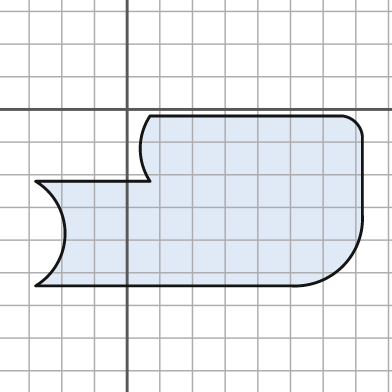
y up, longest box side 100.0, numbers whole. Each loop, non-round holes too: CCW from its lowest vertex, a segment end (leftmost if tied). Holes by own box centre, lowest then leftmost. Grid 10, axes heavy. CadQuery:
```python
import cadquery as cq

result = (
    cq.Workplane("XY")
    .moveTo(-28.0, -54.0)
    .lineTo(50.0, -54.0)
    .threePointArc((66.0, -48.0), (72.0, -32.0))
    .lineTo(72.0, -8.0)
    .threePointArc((70.0, -4.0), (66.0, -2.0))
    .lineTo(7.0, -2.0)
    .threePointArc((4.0, -12.0), (7.0, -22.0))
    .lineTo(-28.0, -22.0)
    .threePointArc((-19.0, -38.0), (-28.0, -54.0))
    .close()
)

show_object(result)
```